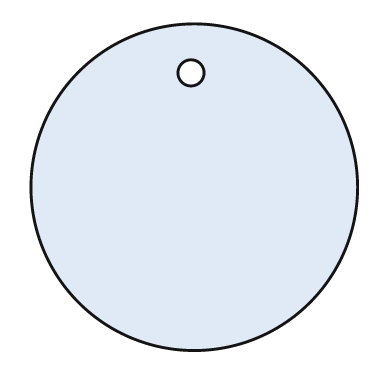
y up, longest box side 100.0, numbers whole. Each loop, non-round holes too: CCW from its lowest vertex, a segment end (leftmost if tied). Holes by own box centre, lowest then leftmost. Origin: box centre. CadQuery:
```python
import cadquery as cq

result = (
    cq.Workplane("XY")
    .moveTo(0.0, 0.0)
    .circle(50.0)
    .moveTo(-1.0, 35.0)
    .circle(4.0)
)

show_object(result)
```